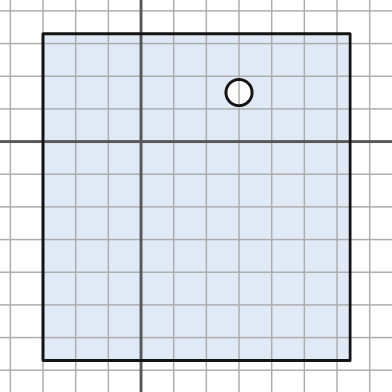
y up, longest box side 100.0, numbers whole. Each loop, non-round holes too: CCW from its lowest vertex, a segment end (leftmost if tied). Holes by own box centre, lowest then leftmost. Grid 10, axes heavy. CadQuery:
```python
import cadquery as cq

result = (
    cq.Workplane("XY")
    .moveTo(-30.0, -67.0)
    .lineTo(64.0, -67.0)
    .lineTo(64.0, 33.0)
    .lineTo(-30.0, 33.0)
    .close()
    .moveTo(30.0, 15.0)
    .circle(4.0)
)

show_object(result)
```